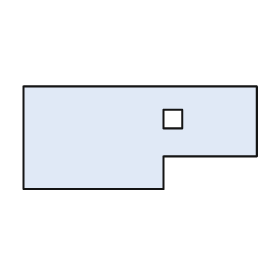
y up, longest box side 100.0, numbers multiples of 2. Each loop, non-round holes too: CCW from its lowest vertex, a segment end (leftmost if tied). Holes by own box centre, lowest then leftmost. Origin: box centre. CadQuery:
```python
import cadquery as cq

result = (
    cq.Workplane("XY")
    .moveTo(-50.0, -22.0)
    .lineTo(10.0, -22.0)
    .lineTo(10.0, -8.0)
    .lineTo(50.0, -8.0)
    .lineTo(50.0, 22.0)
    .lineTo(-50.0, 22.0)
    .close()
    .moveTo(10.0, 4.0)
    .lineTo(18.0, 4.0)
    .lineTo(18.0, 12.0)
    .lineTo(10.0, 12.0)
    .close()
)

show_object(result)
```